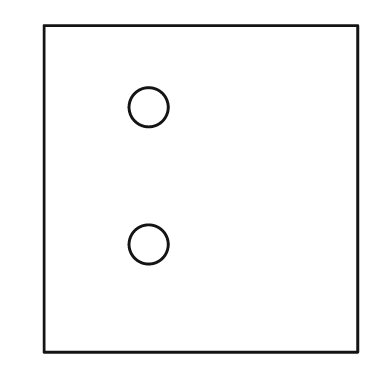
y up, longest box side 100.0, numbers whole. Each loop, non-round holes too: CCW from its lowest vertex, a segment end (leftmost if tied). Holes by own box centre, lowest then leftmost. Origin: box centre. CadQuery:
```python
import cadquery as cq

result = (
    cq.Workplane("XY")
    .moveTo(-48.0, -50.0)
    .lineTo(48.0, -50.0)
    .lineTo(48.0, 50.0)
    .lineTo(-48.0, 50.0)
    .close()
    .moveTo(-16.0, -17.0)
    .circle(6.0)
    .moveTo(-16.0, 25.0)
    .circle(6.0)
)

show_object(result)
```